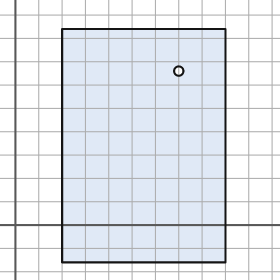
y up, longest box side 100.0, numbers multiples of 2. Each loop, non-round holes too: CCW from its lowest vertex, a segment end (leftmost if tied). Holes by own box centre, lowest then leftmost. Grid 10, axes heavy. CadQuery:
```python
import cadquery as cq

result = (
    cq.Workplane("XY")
    .moveTo(20.0, -16.0)
    .lineTo(90.0, -16.0)
    .lineTo(90.0, 84.0)
    .lineTo(20.0, 84.0)
    .close()
    .moveTo(70.0, 66.0)
    .circle(2.0)
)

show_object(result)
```